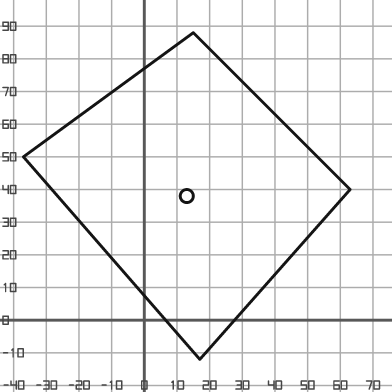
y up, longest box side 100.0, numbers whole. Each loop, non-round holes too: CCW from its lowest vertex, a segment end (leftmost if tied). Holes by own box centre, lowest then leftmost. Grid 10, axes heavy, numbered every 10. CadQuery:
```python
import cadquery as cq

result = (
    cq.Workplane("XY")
    .moveTo(17.0, -12.0)
    .lineTo(63.0, 40.0)
    .lineTo(15.0, 88.0)
    .lineTo(-37.0, 50.0)
    .close()
    .moveTo(13.0, 38.0)
    .circle(2.0)
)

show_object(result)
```